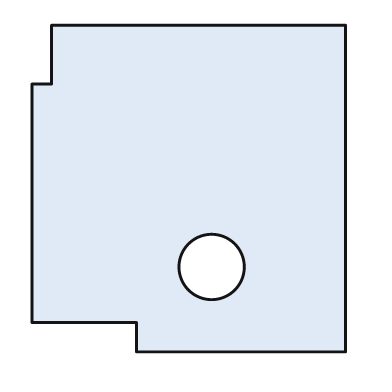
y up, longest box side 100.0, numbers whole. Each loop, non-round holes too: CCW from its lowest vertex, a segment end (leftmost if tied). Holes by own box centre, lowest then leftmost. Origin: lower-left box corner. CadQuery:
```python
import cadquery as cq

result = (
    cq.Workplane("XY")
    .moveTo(32.0, 0.0)
    .lineTo(96.0, 0.0)
    .lineTo(96.0, 100.0)
    .lineTo(6.0, 100.0)
    .lineTo(6.0, 82.0)
    .lineTo(0.0, 82.0)
    .lineTo(0.0, 9.0)
    .lineTo(32.0, 9.0)
    .close()
    .moveTo(55.0, 26.0)
    .circle(10.0)
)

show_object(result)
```